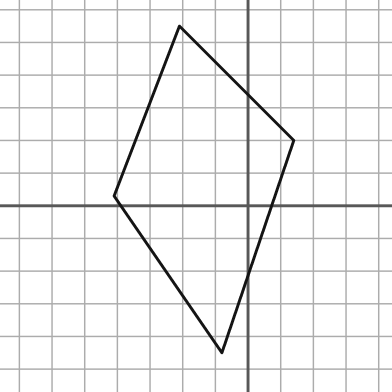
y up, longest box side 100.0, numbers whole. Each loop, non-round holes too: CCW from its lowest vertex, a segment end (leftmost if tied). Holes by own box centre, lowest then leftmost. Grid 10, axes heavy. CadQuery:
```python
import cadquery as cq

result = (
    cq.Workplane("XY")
    .moveTo(-8.0, -45.0)
    .lineTo(14.0, 20.0)
    .lineTo(-21.0, 55.0)
    .lineTo(-41.0, 3.0)
    .close()
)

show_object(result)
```